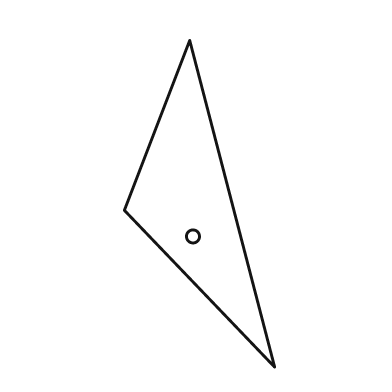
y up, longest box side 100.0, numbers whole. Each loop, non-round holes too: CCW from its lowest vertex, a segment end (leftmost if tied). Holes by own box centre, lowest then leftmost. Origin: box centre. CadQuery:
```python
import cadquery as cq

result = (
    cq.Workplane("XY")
    .moveTo(23.0, -50.0)
    .lineTo(-3.0, 50.0)
    .lineTo(-23.0, -2.0)
    .close()
    .moveTo(-2.0, -10.0)
    .circle(2.0)
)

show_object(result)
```